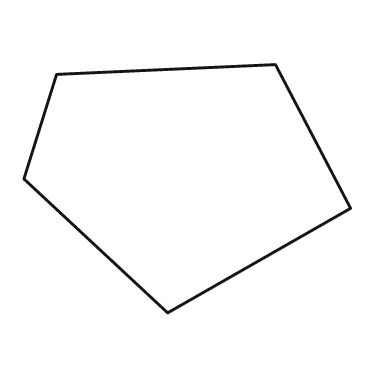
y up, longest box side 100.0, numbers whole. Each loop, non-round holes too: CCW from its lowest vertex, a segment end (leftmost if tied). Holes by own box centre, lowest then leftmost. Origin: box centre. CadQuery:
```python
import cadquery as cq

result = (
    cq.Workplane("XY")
    .moveTo(-6.0, -38.0)
    .lineTo(50.0, -6.0)
    .lineTo(27.0, 38.0)
    .lineTo(-40.0, 35.0)
    .lineTo(-50.0, 3.0)
    .close()
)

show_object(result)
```